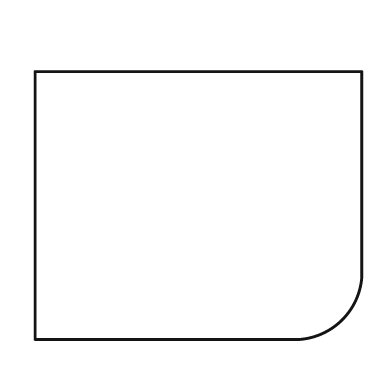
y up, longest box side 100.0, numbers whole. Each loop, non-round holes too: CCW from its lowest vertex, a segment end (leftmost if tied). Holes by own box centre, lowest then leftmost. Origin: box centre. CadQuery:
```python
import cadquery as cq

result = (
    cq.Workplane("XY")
    .moveTo(-50.0, -41.0)
    .lineTo(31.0, -41.0)
    .threePointArc((44.0, -35.0), (50.0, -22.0))
    .lineTo(50.0, 41.0)
    .lineTo(-50.0, 41.0)
    .close()
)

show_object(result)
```